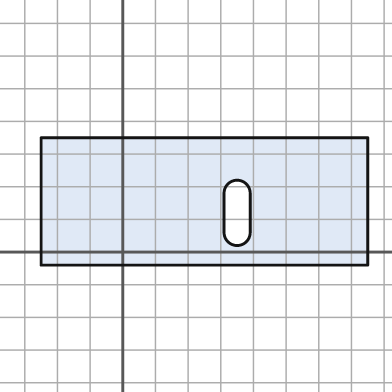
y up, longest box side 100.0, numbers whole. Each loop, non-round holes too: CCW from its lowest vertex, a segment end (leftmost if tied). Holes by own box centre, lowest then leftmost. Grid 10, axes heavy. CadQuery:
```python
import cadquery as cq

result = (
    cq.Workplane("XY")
    .moveTo(-25.0, -4.0)
    .lineTo(75.0, -4.0)
    .lineTo(75.0, 35.0)
    .lineTo(-25.0, 35.0)
    .close()
    .moveTo(31.0, 6.0)
    .threePointArc((35.0, 2.0), (39.0, 6.0))
    .lineTo(39.0, 18.0)
    .threePointArc((35.0, 22.0), (31.0, 18.0))
    .close()
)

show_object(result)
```